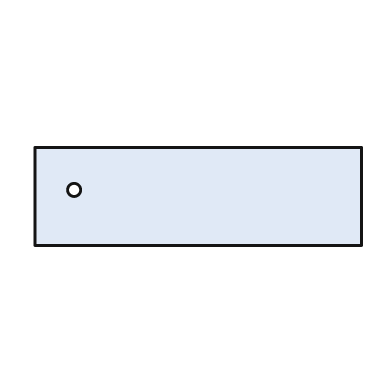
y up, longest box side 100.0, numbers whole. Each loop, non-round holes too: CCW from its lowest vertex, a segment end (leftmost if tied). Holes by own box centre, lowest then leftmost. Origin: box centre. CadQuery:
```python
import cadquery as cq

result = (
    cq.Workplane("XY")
    .moveTo(-50.0, -15.0)
    .lineTo(50.0, -15.0)
    .lineTo(50.0, 15.0)
    .lineTo(-50.0, 15.0)
    .close()
    .moveTo(-38.0, 2.0)
    .circle(2.0)
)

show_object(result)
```